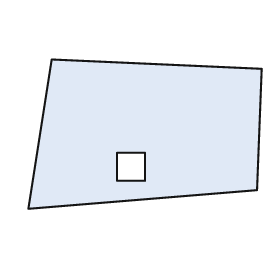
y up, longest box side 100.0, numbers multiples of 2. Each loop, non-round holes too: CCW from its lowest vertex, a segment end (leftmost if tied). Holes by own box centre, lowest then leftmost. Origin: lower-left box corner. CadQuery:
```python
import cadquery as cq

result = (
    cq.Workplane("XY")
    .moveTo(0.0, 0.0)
    .lineTo(98.0, 8.0)
    .lineTo(100.0, 60.0)
    .lineTo(10.0, 64.0)
    .close()
    .moveTo(38.0, 12.0)
    .lineTo(50.0, 12.0)
    .lineTo(50.0, 24.0)
    .lineTo(38.0, 24.0)
    .close()
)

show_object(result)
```